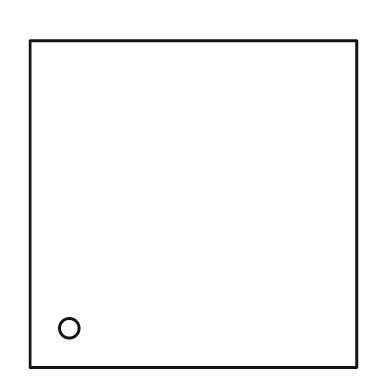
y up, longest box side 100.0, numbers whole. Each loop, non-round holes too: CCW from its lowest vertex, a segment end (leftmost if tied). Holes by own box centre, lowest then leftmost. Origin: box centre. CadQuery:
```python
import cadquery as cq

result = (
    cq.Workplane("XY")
    .moveTo(-50.0, -50.0)
    .lineTo(50.0, -50.0)
    .lineTo(50.0, 50.0)
    .lineTo(-50.0, 50.0)
    .close()
    .moveTo(-38.0, -38.0)
    .circle(3.0)
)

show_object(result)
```